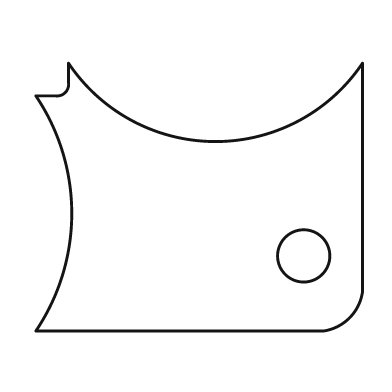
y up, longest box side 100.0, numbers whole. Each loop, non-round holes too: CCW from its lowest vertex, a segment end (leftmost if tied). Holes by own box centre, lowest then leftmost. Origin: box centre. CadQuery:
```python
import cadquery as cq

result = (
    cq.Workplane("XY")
    .moveTo(-50.0, -41.0)
    .lineTo(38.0, -41.0)
    .threePointArc((46.0, -37.0), (50.0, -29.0))
    .lineTo(50.0, 41.0)
    .threePointArc((5.0, 17.0), (-40.0, 41.0))
    .lineTo(-40.0, 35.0)
    .threePointArc((-41.0, 32.0), (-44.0, 31.0))
    .lineTo(-50.0, 31.0)
    .threePointArc((-39.0, -5.0), (-50.0, -41.0))
    .close()
    .moveTo(32.0, -18.0)
    .circle(8.0)
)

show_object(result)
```